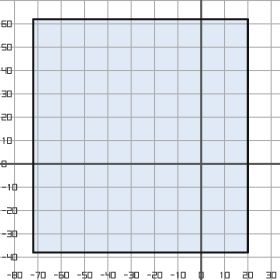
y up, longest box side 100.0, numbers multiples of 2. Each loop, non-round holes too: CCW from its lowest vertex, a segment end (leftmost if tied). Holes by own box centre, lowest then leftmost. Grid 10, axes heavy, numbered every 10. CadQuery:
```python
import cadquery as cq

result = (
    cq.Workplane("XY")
    .moveTo(-72.0, -38.0)
    .lineTo(20.0, -38.0)
    .lineTo(20.0, 62.0)
    .lineTo(-72.0, 62.0)
    .close()
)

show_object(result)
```